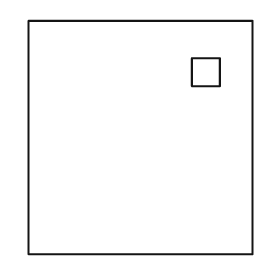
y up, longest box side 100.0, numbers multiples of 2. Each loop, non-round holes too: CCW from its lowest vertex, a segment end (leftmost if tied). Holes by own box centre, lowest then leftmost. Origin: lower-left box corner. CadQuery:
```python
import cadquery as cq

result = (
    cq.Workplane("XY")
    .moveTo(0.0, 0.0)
    .lineTo(96.0, 0.0)
    .lineTo(96.0, 100.0)
    .lineTo(0.0, 100.0)
    .close()
    .moveTo(70.0, 72.0)
    .lineTo(82.0, 72.0)
    .lineTo(82.0, 84.0)
    .lineTo(70.0, 84.0)
    .close()
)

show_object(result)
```